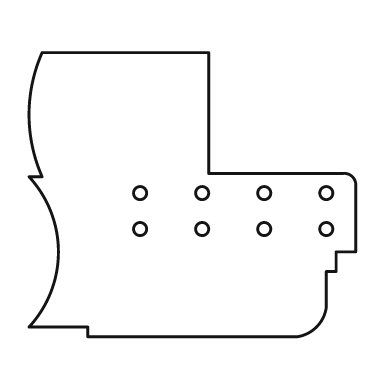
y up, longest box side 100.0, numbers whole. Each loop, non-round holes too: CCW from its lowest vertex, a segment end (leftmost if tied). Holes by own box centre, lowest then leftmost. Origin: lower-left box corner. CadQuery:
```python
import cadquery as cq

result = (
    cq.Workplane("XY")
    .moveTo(18.0, 0.0)
    .lineTo(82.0, 0.0)
    .threePointArc((88.0, 3.0), (91.0, 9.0))
    .lineTo(91.0, 20.0)
    .lineTo(94.0, 20.0)
    .lineTo(94.0, 26.0)
    .lineTo(100.0, 26.0)
    .lineTo(100.0, 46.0)
    .threePointArc((99.0, 49.0), (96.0, 50.0))
    .lineTo(55.0, 50.0)
    .lineTo(55.0, 87.0)
    .lineTo(4.0, 87.0)
    .threePointArc((0.0, 68.0), (4.0, 49.0))
    .lineTo(0.0, 49.0)
    .threePointArc((9.0, 26.0), (0.0, 3.0))
    .lineTo(18.0, 3.0)
    .close()
    .moveTo(34.0, 33.0)
    .circle(2.0)
    .moveTo(53.0, 33.0)
    .circle(2.0)
    .moveTo(72.0, 33.0)
    .circle(2.0)
    .moveTo(91.0, 33.0)
    .circle(2.0)
    .moveTo(34.0, 44.0)
    .circle(2.0)
    .moveTo(53.0, 44.0)
    .circle(2.0)
    .moveTo(72.0, 44.0)
    .circle(2.0)
    .moveTo(91.0, 44.0)
    .circle(2.0)
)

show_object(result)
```